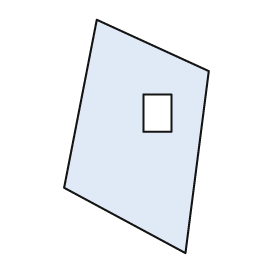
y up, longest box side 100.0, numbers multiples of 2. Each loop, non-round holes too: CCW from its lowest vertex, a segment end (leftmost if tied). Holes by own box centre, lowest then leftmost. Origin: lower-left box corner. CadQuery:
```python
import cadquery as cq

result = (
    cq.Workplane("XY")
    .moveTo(52.0, 0.0)
    .lineTo(62.0, 78.0)
    .lineTo(14.0, 100.0)
    .lineTo(0.0, 28.0)
    .close()
    .moveTo(34.0, 52.0)
    .lineTo(46.0, 52.0)
    .lineTo(46.0, 68.0)
    .lineTo(34.0, 68.0)
    .close()
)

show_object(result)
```